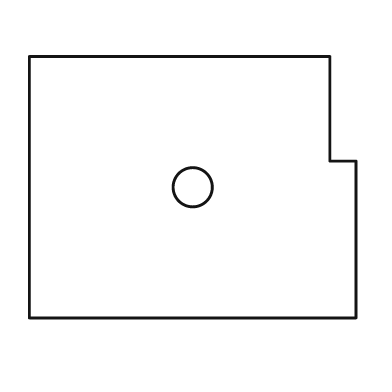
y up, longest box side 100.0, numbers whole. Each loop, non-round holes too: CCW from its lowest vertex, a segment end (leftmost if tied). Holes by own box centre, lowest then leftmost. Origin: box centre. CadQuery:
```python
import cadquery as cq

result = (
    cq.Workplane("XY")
    .moveTo(-50.0, -40.0)
    .lineTo(50.0, -40.0)
    .lineTo(50.0, 8.0)
    .lineTo(42.0, 8.0)
    .lineTo(42.0, 40.0)
    .lineTo(-50.0, 40.0)
    .close()
    .moveTo(0.0, 0.0)
    .circle(6.0)
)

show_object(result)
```